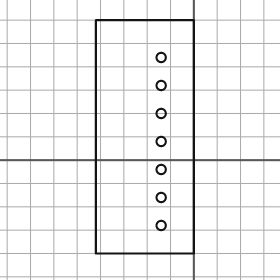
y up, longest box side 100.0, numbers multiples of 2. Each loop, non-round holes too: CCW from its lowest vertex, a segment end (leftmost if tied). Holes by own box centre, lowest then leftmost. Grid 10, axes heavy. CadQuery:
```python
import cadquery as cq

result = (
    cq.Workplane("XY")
    .moveTo(-42.0, -40.0)
    .lineTo(0.0, -40.0)
    .lineTo(0.0, 60.0)
    .lineTo(-42.0, 60.0)
    .close()
    .moveTo(-14.0, -28.0)
    .circle(2.0)
    .moveTo(-14.0, -16.0)
    .circle(2.0)
    .moveTo(-14.0, -4.0)
    .circle(2.0)
    .moveTo(-14.0, 8.0)
    .circle(2.0)
    .moveTo(-14.0, 20.0)
    .circle(2.0)
    .moveTo(-14.0, 32.0)
    .circle(2.0)
    .moveTo(-14.0, 44.0)
    .circle(2.0)
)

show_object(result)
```